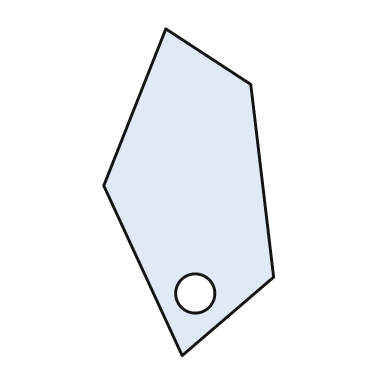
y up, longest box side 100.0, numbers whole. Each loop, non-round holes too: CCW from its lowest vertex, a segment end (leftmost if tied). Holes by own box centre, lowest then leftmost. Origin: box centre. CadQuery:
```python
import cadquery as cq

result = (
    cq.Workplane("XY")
    .moveTo(-2.0, -50.0)
    .lineTo(26.0, -26.0)
    .lineTo(19.0, 33.0)
    .lineTo(-7.0, 50.0)
    .lineTo(-26.0, 2.0)
    .close()
    .moveTo(2.0, -31.0)
    .circle(6.0)
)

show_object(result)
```